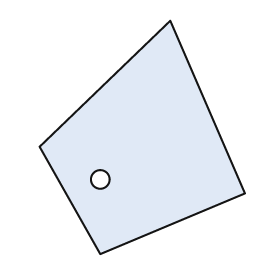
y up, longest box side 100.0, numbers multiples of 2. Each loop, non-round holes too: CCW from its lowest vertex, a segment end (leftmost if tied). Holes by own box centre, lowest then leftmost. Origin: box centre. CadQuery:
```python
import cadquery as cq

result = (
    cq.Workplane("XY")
    .moveTo(-18.0, -50.0)
    .lineTo(44.0, -24.0)
    .lineTo(12.0, 50.0)
    .lineTo(-44.0, -4.0)
    .close()
    .moveTo(-18.0, -18.0)
    .circle(4.0)
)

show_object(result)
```